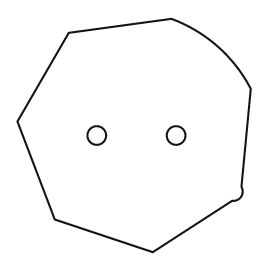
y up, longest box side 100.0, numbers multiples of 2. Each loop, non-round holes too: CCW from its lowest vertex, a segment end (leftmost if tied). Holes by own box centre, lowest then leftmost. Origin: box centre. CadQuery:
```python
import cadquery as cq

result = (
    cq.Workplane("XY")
    .moveTo(8.0, -50.0)
    .lineTo(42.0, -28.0)
    .threePointArc((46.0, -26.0), (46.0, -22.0))
    .lineTo(50.0, 20.0)
    .threePointArc((36.0, 38.0), (16.0, 50.0))
    .lineTo(-28.0, 44.0)
    .lineTo(-50.0, 6.0)
    .lineTo(-34.0, -36.0)
    .close()
    .moveTo(-16.0, 0.0)
    .circle(4.0)
    .moveTo(18.0, 0.0)
    .circle(4.0)
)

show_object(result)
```